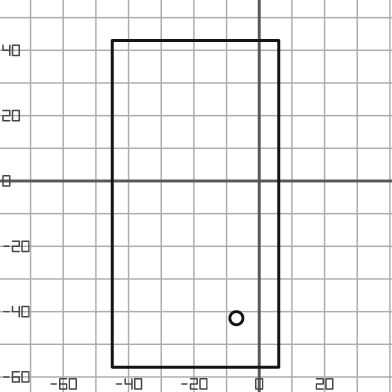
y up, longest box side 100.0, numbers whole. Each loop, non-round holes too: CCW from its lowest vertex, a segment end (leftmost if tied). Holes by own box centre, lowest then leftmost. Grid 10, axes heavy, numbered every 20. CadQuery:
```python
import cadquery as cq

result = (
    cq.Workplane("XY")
    .moveTo(-45.0, -57.0)
    .lineTo(6.0, -57.0)
    .lineTo(6.0, 43.0)
    .lineTo(-45.0, 43.0)
    .close()
    .moveTo(-7.0, -42.0)
    .circle(2.0)
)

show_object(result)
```